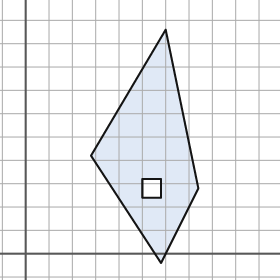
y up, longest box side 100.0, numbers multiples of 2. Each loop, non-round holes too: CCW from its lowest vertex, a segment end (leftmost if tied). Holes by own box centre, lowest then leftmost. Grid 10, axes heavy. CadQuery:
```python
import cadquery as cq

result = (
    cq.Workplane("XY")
    .moveTo(58.0, -4.0)
    .lineTo(74.0, 28.0)
    .lineTo(60.0, 96.0)
    .lineTo(28.0, 42.0)
    .close()
    .moveTo(50.0, 24.0)
    .lineTo(58.0, 24.0)
    .lineTo(58.0, 32.0)
    .lineTo(50.0, 32.0)
    .close()
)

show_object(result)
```